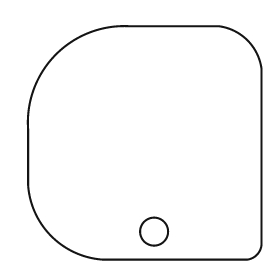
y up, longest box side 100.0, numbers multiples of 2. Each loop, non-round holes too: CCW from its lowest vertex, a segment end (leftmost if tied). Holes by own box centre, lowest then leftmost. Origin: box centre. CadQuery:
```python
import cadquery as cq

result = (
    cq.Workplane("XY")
    .moveTo(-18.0, -50.0)
    .lineTo(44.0, -50.0)
    .threePointArc((48.0, -48.0), (50.0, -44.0))
    .lineTo(50.0, 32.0)
    .threePointArc((44.0, 44.0), (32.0, 50.0))
    .lineTo(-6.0, 50.0)
    .threePointArc((-38.0, 38.0), (-50.0, 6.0))
    .lineTo(-50.0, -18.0)
    .threePointArc((-40.0, -40.0), (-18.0, -50.0))
    .close()
    .moveTo(4.0, -38.0)
    .circle(6.0)
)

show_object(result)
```